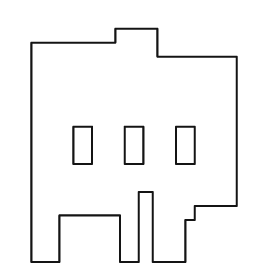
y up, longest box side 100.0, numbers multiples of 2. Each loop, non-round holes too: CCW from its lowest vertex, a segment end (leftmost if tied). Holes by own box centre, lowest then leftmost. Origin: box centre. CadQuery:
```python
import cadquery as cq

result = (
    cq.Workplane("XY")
    .moveTo(-44.0, -50.0)
    .lineTo(-32.0, -50.0)
    .lineTo(-32.0, -30.0)
    .lineTo(-6.0, -30.0)
    .lineTo(-6.0, -50.0)
    .lineTo(2.0, -50.0)
    .lineTo(2.0, -20.0)
    .lineTo(8.0, -20.0)
    .lineTo(8.0, -50.0)
    .lineTo(22.0, -50.0)
    .lineTo(22.0, -32.0)
    .lineTo(26.0, -32.0)
    .lineTo(26.0, -26.0)
    .lineTo(44.0, -26.0)
    .lineTo(44.0, 38.0)
    .lineTo(10.0, 38.0)
    .lineTo(10.0, 50.0)
    .lineTo(-8.0, 50.0)
    .lineTo(-8.0, 44.0)
    .lineTo(-44.0, 44.0)
    .close()
    .moveTo(-26.0, -8.0)
    .lineTo(-18.0, -8.0)
    .lineTo(-18.0, 8.0)
    .lineTo(-26.0, 8.0)
    .close()
    .moveTo(-4.0, -8.0)
    .lineTo(4.0, -8.0)
    .lineTo(4.0, 8.0)
    .lineTo(-4.0, 8.0)
    .close()
    .moveTo(18.0, -8.0)
    .lineTo(26.0, -8.0)
    .lineTo(26.0, 8.0)
    .lineTo(18.0, 8.0)
    .close()
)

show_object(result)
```